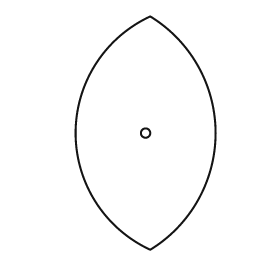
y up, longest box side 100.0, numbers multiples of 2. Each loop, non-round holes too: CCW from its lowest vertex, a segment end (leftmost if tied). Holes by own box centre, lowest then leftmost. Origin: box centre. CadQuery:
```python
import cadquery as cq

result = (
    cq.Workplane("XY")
    .moveTo(2.0, -50.0)
    .threePointArc((30.0, 0.0), (2.0, 50.0))
    .threePointArc((-30.0, 0.0), (2.0, -50.0))
    .close()
    .moveTo(0.0, 0.0)
    .circle(2.0)
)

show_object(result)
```